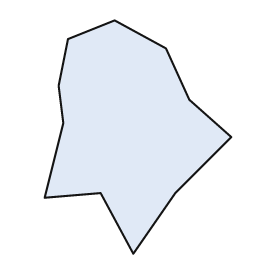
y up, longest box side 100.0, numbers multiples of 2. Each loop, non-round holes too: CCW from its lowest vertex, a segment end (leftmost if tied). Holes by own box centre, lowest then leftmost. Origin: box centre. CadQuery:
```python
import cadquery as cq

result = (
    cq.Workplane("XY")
    .moveTo(-2.0, -50.0)
    .lineTo(16.0, -24.0)
    .lineTo(40.0, 0.0)
    .lineTo(22.0, 16.0)
    .lineTo(12.0, 38.0)
    .lineTo(-10.0, 50.0)
    .lineTo(-30.0, 42.0)
    .lineTo(-34.0, 22.0)
    .lineTo(-32.0, 6.0)
    .lineTo(-40.0, -26.0)
    .lineTo(-16.0, -24.0)
    .close()
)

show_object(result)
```